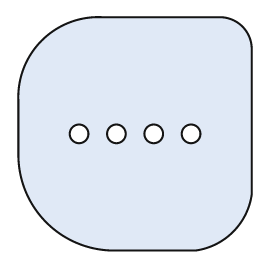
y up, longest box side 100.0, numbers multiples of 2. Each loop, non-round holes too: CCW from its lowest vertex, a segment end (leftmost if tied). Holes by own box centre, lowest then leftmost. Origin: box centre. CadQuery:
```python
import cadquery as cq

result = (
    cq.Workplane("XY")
    .moveTo(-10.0, -50.0)
    .lineTo(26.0, -50.0)
    .threePointArc((42.0, -42.0), (50.0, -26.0))
    .lineTo(50.0, 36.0)
    .threePointArc((46.0, 46.0), (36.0, 50.0))
    .lineTo(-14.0, 50.0)
    .threePointArc((-40.0, 40.0), (-50.0, 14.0))
    .lineTo(-50.0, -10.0)
    .threePointArc((-38.0, -38.0), (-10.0, -50.0))
    .close()
    .moveTo(-24.0, 0.0)
    .circle(4.0)
    .moveTo(-8.0, 0.0)
    .circle(4.0)
    .moveTo(8.0, 0.0)
    .circle(4.0)
    .moveTo(24.0, 0.0)
    .circle(4.0)
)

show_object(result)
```